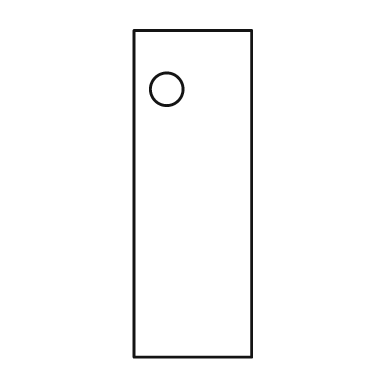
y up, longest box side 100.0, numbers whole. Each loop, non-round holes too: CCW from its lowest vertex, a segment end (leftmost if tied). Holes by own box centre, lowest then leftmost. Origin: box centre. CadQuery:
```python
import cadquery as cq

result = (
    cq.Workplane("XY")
    .moveTo(-18.0, -50.0)
    .lineTo(18.0, -50.0)
    .lineTo(18.0, 50.0)
    .lineTo(-18.0, 50.0)
    .close()
    .moveTo(-8.0, 32.0)
    .circle(5.0)
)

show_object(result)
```